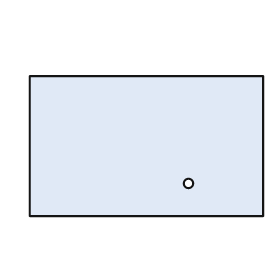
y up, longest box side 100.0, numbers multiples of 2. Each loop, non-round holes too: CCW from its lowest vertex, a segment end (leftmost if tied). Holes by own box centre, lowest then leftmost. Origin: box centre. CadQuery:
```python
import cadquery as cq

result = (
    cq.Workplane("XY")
    .moveTo(-50.0, -30.0)
    .lineTo(50.0, -30.0)
    .lineTo(50.0, 30.0)
    .lineTo(-50.0, 30.0)
    .close()
    .moveTo(18.0, -16.0)
    .circle(2.0)
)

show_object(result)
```